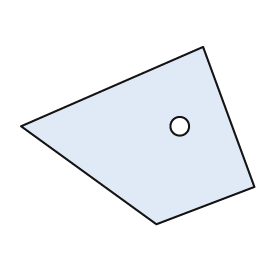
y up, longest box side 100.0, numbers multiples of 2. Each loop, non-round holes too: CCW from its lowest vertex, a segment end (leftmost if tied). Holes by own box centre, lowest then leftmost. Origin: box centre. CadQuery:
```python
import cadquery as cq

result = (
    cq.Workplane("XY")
    .moveTo(8.0, -38.0)
    .lineTo(50.0, -22.0)
    .lineTo(28.0, 38.0)
    .lineTo(-50.0, 4.0)
    .close()
    .moveTo(18.0, 4.0)
    .circle(4.0)
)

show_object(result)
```